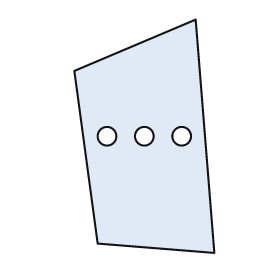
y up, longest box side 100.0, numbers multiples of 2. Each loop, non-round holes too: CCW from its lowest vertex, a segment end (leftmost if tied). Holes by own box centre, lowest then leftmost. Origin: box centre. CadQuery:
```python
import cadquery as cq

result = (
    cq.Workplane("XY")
    .moveTo(30.0, -50.0)
    .lineTo(22.0, 50.0)
    .lineTo(-30.0, 28.0)
    .lineTo(-20.0, -46.0)
    .close()
    .moveTo(-16.0, 0.0)
    .circle(4.0)
    .moveTo(0.0, 0.0)
    .circle(4.0)
    .moveTo(16.0, 0.0)
    .circle(4.0)
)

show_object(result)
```